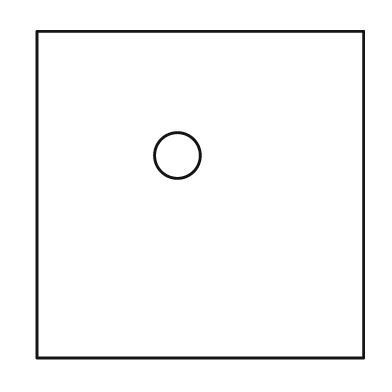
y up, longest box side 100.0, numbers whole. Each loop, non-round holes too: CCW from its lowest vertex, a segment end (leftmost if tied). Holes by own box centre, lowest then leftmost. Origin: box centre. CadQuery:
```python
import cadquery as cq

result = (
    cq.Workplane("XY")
    .moveTo(-50.0, -50.0)
    .lineTo(50.0, -50.0)
    .lineTo(50.0, 50.0)
    .lineTo(-50.0, 50.0)
    .close()
    .moveTo(-7.0, 12.0)
    .circle(7.0)
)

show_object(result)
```